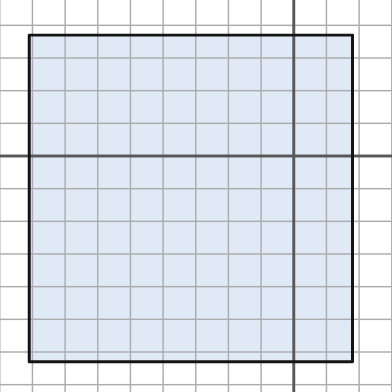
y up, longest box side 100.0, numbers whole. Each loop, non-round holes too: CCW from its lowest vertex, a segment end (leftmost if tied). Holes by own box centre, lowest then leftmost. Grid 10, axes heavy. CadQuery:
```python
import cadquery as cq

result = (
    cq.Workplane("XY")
    .moveTo(-81.0, -63.0)
    .lineTo(18.0, -63.0)
    .lineTo(18.0, 37.0)
    .lineTo(-81.0, 37.0)
    .close()
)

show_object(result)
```